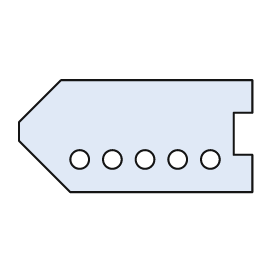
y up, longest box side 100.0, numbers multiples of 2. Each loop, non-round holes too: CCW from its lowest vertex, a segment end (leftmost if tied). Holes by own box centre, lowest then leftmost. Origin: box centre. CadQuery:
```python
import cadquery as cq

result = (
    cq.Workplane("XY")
    .moveTo(-28.0, -24.0)
    .lineTo(50.0, -24.0)
    .lineTo(50.0, -8.0)
    .lineTo(42.0, -8.0)
    .lineTo(42.0, 10.0)
    .lineTo(50.0, 10.0)
    .lineTo(50.0, 24.0)
    .lineTo(-32.0, 24.0)
    .lineTo(-50.0, 6.0)
    .lineTo(-50.0, -2.0)
    .close()
    .moveTo(-24.0, -10.0)
    .circle(4.0)
    .moveTo(-10.0, -10.0)
    .circle(4.0)
    .moveTo(4.0, -10.0)
    .circle(4.0)
    .moveTo(18.0, -10.0)
    .circle(4.0)
    .moveTo(32.0, -10.0)
    .circle(4.0)
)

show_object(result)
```